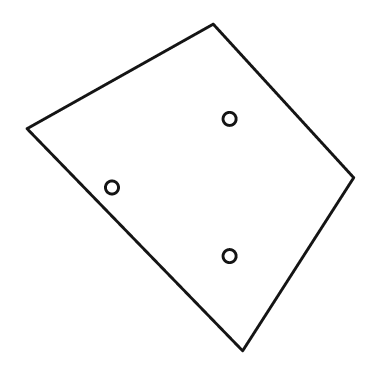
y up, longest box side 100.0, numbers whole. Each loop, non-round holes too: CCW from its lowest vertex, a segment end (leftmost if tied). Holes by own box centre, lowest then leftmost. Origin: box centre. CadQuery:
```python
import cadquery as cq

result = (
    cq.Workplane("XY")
    .moveTo(16.0, -50.0)
    .lineTo(50.0, 3.0)
    .lineTo(7.0, 50.0)
    .lineTo(-50.0, 18.0)
    .close()
    .moveTo(12.0, -21.0)
    .circle(2.0)
    .moveTo(-24.0, 0.0)
    .circle(2.0)
    .moveTo(12.0, 21.0)
    .circle(2.0)
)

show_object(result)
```